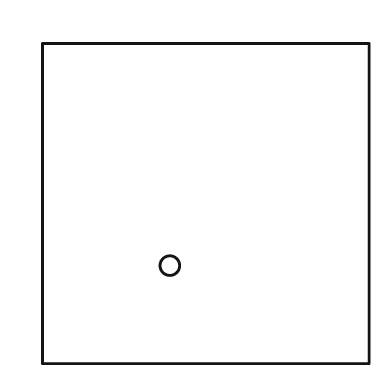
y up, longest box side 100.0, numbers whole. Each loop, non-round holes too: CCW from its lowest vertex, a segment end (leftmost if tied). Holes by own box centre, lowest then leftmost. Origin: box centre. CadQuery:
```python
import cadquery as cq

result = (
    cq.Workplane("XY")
    .moveTo(-50.0, -49.0)
    .lineTo(50.0, -49.0)
    .lineTo(50.0, 49.0)
    .lineTo(-50.0, 49.0)
    .close()
    .moveTo(-11.0, -19.0)
    .circle(3.0)
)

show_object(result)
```